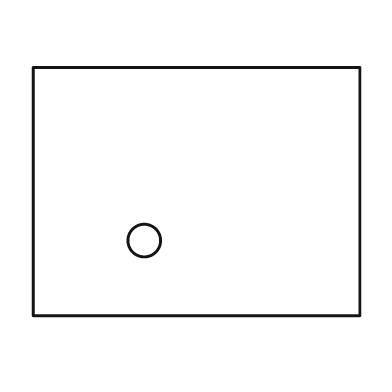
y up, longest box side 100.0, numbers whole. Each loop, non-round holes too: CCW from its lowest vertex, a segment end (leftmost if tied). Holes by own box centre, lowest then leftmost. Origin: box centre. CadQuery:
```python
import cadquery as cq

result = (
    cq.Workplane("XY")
    .moveTo(-50.0, -38.0)
    .lineTo(50.0, -38.0)
    .lineTo(50.0, 38.0)
    .lineTo(-50.0, 38.0)
    .close()
    .moveTo(-16.0, -15.0)
    .circle(5.0)
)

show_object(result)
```